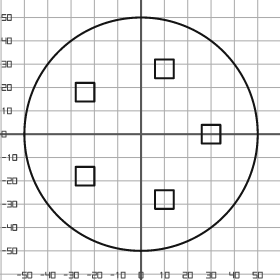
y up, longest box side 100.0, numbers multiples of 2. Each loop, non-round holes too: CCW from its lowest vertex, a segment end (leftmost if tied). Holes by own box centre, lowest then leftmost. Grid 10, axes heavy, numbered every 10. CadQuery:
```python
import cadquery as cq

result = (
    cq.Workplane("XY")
    .moveTo(0.0, 0.0)
    .circle(50.0)
    .moveTo(6.0, -32.0)
    .lineTo(14.0, -32.0)
    .lineTo(14.0, -24.0)
    .lineTo(6.0, -24.0)
    .close()
    .moveTo(-28.0, -22.0)
    .lineTo(-20.0, -22.0)
    .lineTo(-20.0, -14.0)
    .lineTo(-28.0, -14.0)
    .close()
    .moveTo(26.0, -4.0)
    .lineTo(34.0, -4.0)
    .lineTo(34.0, 4.0)
    .lineTo(26.0, 4.0)
    .close()
    .moveTo(-28.0, 14.0)
    .lineTo(-20.0, 14.0)
    .lineTo(-20.0, 22.0)
    .lineTo(-28.0, 22.0)
    .close()
    .moveTo(6.0, 24.0)
    .lineTo(14.0, 24.0)
    .lineTo(14.0, 32.0)
    .lineTo(6.0, 32.0)
    .close()
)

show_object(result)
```